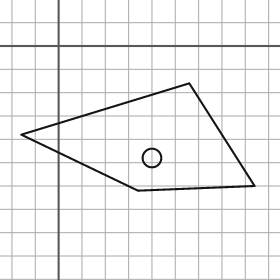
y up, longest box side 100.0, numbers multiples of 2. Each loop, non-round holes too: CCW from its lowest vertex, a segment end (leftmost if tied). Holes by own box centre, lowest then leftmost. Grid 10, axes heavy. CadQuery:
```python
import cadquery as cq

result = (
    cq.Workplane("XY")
    .moveTo(34.0, -62.0)
    .lineTo(84.0, -60.0)
    .lineTo(56.0, -16.0)
    .lineTo(-16.0, -38.0)
    .close()
    .moveTo(40.0, -48.0)
    .circle(4.0)
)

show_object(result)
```